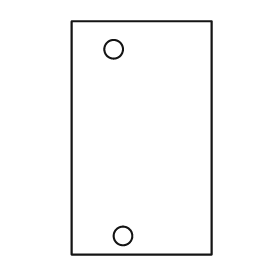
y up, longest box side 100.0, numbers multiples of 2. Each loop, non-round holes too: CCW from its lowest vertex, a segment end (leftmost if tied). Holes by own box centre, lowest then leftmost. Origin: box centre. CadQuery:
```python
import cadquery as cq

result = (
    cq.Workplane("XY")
    .moveTo(-30.0, -50.0)
    .lineTo(30.0, -50.0)
    .lineTo(30.0, 50.0)
    .lineTo(-30.0, 50.0)
    .close()
    .moveTo(-8.0, -42.0)
    .circle(4.0)
    .moveTo(-12.0, 38.0)
    .circle(4.0)
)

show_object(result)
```